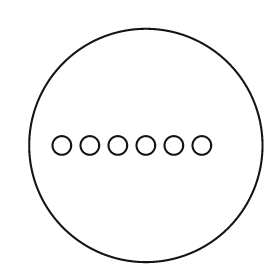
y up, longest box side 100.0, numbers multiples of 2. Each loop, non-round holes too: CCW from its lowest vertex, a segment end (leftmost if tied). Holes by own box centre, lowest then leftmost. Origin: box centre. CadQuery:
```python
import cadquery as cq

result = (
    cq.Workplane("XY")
    .moveTo(0.0, 0.0)
    .circle(50.0)
    .moveTo(-36.0, 0.0)
    .circle(4.0)
    .moveTo(-24.0, 0.0)
    .circle(4.0)
    .moveTo(-12.0, 0.0)
    .circle(4.0)
    .moveTo(0.0, 0.0)
    .circle(4.0)
    .moveTo(12.0, 0.0)
    .circle(4.0)
    .moveTo(24.0, 0.0)
    .circle(4.0)
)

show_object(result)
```